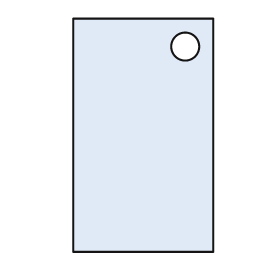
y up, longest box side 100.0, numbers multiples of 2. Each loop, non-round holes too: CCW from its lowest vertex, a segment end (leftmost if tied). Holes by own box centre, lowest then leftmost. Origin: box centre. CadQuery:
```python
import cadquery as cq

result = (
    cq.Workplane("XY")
    .moveTo(-30.0, -50.0)
    .lineTo(30.0, -50.0)
    .lineTo(30.0, 50.0)
    .lineTo(-30.0, 50.0)
    .close()
    .moveTo(18.0, 38.0)
    .circle(6.0)
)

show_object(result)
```